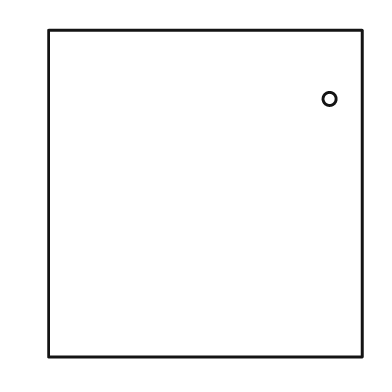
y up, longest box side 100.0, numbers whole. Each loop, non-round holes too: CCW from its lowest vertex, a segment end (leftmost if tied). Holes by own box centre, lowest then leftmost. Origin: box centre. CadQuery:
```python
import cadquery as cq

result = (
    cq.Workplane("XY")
    .moveTo(-48.0, -50.0)
    .lineTo(48.0, -50.0)
    .lineTo(48.0, 50.0)
    .lineTo(-48.0, 50.0)
    .close()
    .moveTo(38.0, 29.0)
    .circle(2.0)
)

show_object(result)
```